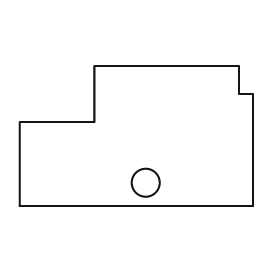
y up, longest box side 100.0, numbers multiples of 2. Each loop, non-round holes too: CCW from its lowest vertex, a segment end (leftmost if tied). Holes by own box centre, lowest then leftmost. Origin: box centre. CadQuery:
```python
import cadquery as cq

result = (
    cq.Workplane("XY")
    .moveTo(-50.0, -30.0)
    .lineTo(50.0, -30.0)
    .lineTo(50.0, 18.0)
    .lineTo(44.0, 18.0)
    .lineTo(44.0, 30.0)
    .lineTo(-18.0, 30.0)
    .lineTo(-18.0, 6.0)
    .lineTo(-50.0, 6.0)
    .close()
    .moveTo(4.0, -20.0)
    .circle(6.0)
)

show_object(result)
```